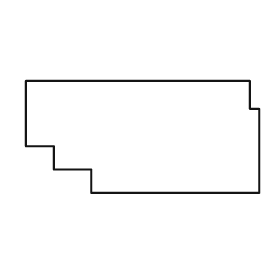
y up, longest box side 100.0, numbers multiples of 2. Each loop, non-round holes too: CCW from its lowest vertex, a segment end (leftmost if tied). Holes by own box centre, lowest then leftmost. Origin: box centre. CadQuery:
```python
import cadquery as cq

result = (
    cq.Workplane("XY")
    .moveTo(-22.0, -24.0)
    .lineTo(50.0, -24.0)
    .lineTo(50.0, 12.0)
    .lineTo(46.0, 12.0)
    .lineTo(46.0, 24.0)
    .lineTo(-50.0, 24.0)
    .lineTo(-50.0, -4.0)
    .lineTo(-38.0, -4.0)
    .lineTo(-38.0, -14.0)
    .lineTo(-22.0, -14.0)
    .close()
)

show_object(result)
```